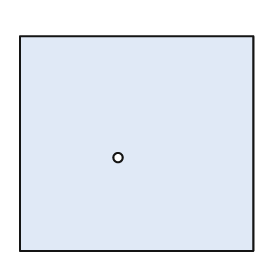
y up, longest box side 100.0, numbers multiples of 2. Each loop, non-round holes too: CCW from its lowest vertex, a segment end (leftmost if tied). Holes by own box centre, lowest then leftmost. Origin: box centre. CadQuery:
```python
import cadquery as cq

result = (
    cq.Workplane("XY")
    .moveTo(-50.0, -46.0)
    .lineTo(50.0, -46.0)
    .lineTo(50.0, 46.0)
    .lineTo(-50.0, 46.0)
    .close()
    .moveTo(-8.0, -6.0)
    .circle(2.0)
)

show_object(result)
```